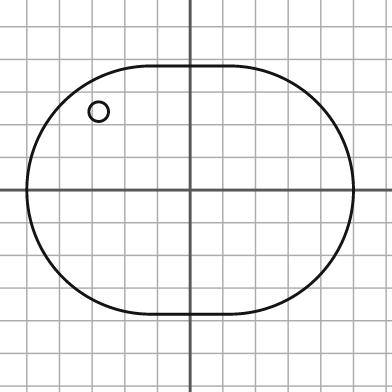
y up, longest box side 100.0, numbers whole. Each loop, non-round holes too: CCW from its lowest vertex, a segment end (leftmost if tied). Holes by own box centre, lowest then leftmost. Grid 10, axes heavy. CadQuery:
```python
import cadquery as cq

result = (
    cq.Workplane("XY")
    .moveTo(-12.0, -38.0)
    .lineTo(12.0, -38.0)
    .threePointArc((50.0, 0.0), (12.0, 38.0))
    .lineTo(-12.0, 38.0)
    .threePointArc((-50.0, 0.0), (-12.0, -38.0))
    .close()
    .moveTo(-28.0, 24.0)
    .circle(3.0)
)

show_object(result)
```